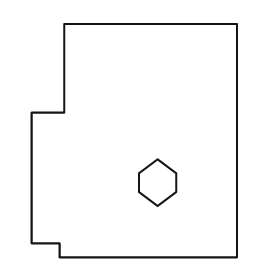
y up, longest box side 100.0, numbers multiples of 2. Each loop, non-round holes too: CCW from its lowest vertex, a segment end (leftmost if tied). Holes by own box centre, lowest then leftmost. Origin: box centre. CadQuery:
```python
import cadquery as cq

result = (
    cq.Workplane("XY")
    .moveTo(-32.0, -50.0)
    .lineTo(44.0, -50.0)
    .lineTo(44.0, 50.0)
    .lineTo(-30.0, 50.0)
    .lineTo(-30.0, 12.0)
    .lineTo(-44.0, 12.0)
    .lineTo(-44.0, -44.0)
    .lineTo(-32.0, -44.0)
    .close()
    .moveTo(10.0, -28.0)
    .lineTo(18.0, -22.0)
    .lineTo(18.0, -14.0)
    .lineTo(10.0, -8.0)
    .lineTo(2.0, -14.0)
    .lineTo(2.0, -22.0)
    .close()
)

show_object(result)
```